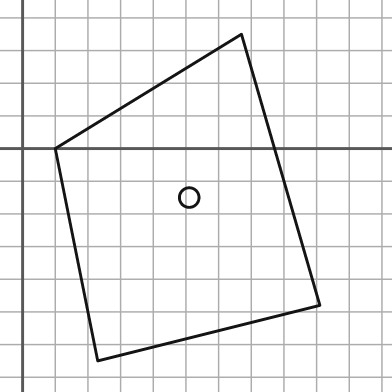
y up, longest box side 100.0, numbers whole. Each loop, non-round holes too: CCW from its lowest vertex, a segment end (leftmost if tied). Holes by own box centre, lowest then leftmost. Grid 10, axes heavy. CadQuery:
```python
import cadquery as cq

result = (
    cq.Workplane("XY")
    .moveTo(23.0, -65.0)
    .lineTo(91.0, -48.0)
    .lineTo(67.0, 35.0)
    .lineTo(10.0, 0.0)
    .close()
    .moveTo(51.0, -15.0)
    .circle(3.0)
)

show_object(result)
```